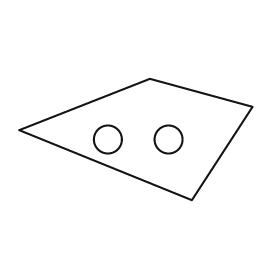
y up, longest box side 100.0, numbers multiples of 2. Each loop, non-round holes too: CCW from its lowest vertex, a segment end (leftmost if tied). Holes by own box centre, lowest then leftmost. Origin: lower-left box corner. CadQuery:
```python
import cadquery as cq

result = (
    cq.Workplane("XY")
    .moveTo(74.0, 0.0)
    .lineTo(100.0, 40.0)
    .lineTo(56.0, 52.0)
    .lineTo(0.0, 30.0)
    .close()
    .moveTo(38.0, 26.0)
    .circle(6.0)
    .moveTo(64.0, 26.0)
    .circle(6.0)
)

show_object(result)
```